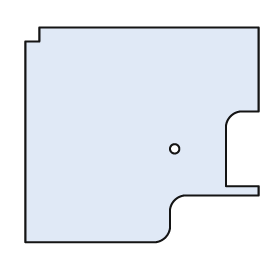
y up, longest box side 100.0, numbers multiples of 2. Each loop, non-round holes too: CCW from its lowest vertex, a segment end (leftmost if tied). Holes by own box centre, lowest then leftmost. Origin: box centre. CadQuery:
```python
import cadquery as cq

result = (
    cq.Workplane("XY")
    .moveTo(-50.0, -46.0)
    .lineTo(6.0, -46.0)
    .threePointArc((10.0, -44.0), (12.0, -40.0))
    .lineTo(12.0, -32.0)
    .threePointArc((14.0, -28.0), (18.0, -26.0))
    .lineTo(50.0, -26.0)
    .lineTo(50.0, -22.0)
    .lineTo(36.0, -22.0)
    .lineTo(36.0, 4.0)
    .threePointArc((38.0, 8.0), (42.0, 10.0))
    .lineTo(50.0, 10.0)
    .lineTo(50.0, 46.0)
    .lineTo(-44.0, 46.0)
    .lineTo(-44.0, 40.0)
    .lineTo(-50.0, 40.0)
    .close()
    .moveTo(14.0, -6.0)
    .circle(2.0)
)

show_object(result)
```